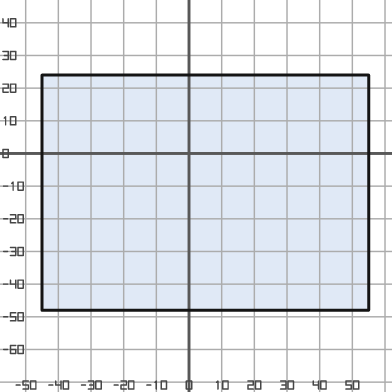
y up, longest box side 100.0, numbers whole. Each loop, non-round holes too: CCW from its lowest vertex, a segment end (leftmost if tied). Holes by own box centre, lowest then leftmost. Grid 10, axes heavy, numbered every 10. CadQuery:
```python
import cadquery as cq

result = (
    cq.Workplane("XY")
    .moveTo(-45.0, -48.0)
    .lineTo(55.0, -48.0)
    .lineTo(55.0, 24.0)
    .lineTo(-45.0, 24.0)
    .close()
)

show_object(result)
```